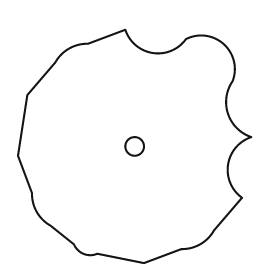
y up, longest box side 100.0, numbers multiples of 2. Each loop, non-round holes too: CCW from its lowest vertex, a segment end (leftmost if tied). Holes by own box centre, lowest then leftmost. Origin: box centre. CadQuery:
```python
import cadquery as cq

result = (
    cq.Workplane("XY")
    .moveTo(4.0, -50.0)
    .lineTo(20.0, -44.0)
    .threePointArc((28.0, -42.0), (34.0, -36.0))
    .lineTo(46.0, -22.0)
    .threePointArc((40.0, -8.0), (50.0, 4.0))
    .threePointArc((40.0, 14.0), (42.0, 28.0))
    .threePointArc((38.0, 44.0), (22.0, 46.0))
    .threePointArc((8.0, 40.0), (-4.0, 50.0))
    .lineTo(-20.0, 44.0)
    .threePointArc((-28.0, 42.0), (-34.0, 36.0))
    .lineTo(-46.0, 22.0)
    .lineTo(-50.0, -4.0)
    .lineTo(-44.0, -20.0)
    .threePointArc((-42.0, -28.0), (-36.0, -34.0))
    .lineTo(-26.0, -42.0)
    .threePointArc((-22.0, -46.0), (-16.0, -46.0))
    .close()
    .moveTo(0.0, 0.0)
    .circle(4.0)
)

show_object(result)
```